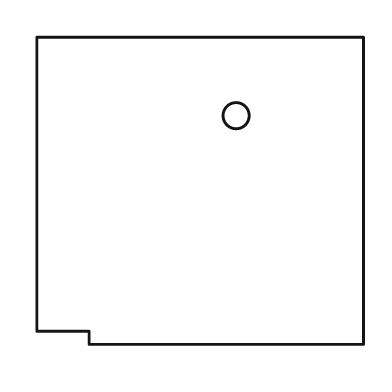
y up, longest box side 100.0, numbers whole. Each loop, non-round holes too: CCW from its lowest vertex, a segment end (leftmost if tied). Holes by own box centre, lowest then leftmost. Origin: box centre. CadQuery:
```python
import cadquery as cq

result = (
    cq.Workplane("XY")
    .moveTo(-34.0, -47.0)
    .lineTo(50.0, -47.0)
    .lineTo(50.0, 47.0)
    .lineTo(-50.0, 47.0)
    .lineTo(-50.0, -43.0)
    .lineTo(-34.0, -43.0)
    .close()
    .moveTo(11.0, 23.0)
    .circle(4.0)
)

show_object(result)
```